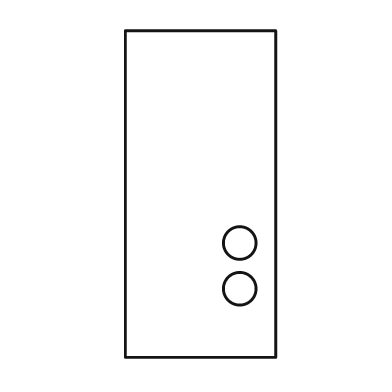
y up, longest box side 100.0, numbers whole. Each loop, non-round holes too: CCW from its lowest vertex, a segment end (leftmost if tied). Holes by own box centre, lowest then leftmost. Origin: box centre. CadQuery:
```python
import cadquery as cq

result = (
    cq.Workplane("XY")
    .moveTo(-23.0, -50.0)
    .lineTo(23.0, -50.0)
    .lineTo(23.0, 50.0)
    .lineTo(-23.0, 50.0)
    .close()
    .moveTo(12.0, -29.0)
    .circle(5.0)
    .moveTo(12.0, -15.0)
    .circle(5.0)
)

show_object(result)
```